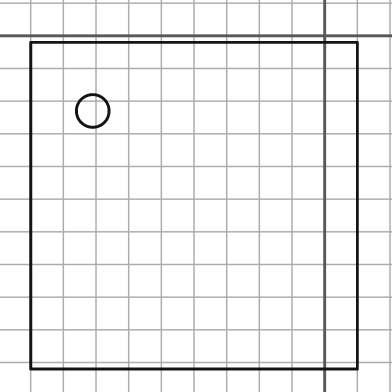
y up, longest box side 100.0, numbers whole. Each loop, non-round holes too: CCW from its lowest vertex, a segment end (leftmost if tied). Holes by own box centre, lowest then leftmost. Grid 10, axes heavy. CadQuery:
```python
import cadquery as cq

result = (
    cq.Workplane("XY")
    .moveTo(-90.0, -102.0)
    .lineTo(10.0, -102.0)
    .lineTo(10.0, -2.0)
    .lineTo(-90.0, -2.0)
    .close()
    .moveTo(-71.0, -23.0)
    .circle(5.0)
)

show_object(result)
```